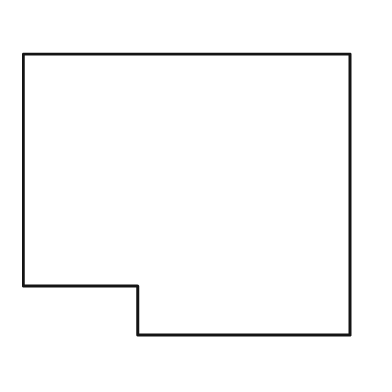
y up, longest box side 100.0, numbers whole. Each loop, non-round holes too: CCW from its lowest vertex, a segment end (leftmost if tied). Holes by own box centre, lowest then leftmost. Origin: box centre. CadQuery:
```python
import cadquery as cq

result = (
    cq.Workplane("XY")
    .moveTo(-15.0, -43.0)
    .lineTo(50.0, -43.0)
    .lineTo(50.0, 43.0)
    .lineTo(-50.0, 43.0)
    .lineTo(-50.0, -28.0)
    .lineTo(-15.0, -28.0)
    .close()
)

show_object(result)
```